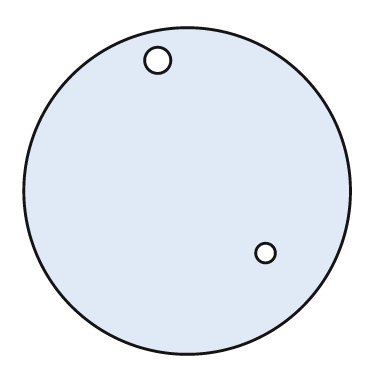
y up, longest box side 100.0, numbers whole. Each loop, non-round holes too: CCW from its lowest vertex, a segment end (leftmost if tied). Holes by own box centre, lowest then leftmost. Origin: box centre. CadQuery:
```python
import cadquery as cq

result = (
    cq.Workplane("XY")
    .moveTo(0.0, 0.0)
    .circle(50.0)
    .moveTo(24.0, -19.0)
    .circle(3.0)
    .moveTo(-9.0, 40.0)
    .circle(4.0)
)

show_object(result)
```